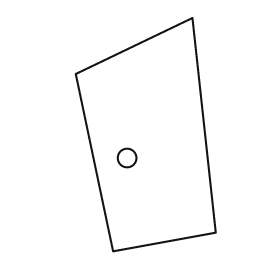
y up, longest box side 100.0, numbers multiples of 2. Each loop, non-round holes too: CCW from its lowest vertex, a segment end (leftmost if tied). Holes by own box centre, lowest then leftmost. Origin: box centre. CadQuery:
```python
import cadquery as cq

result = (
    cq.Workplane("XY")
    .moveTo(-14.0, -50.0)
    .lineTo(30.0, -42.0)
    .lineTo(20.0, 50.0)
    .lineTo(-30.0, 26.0)
    .close()
    .moveTo(-8.0, -10.0)
    .circle(4.0)
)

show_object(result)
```